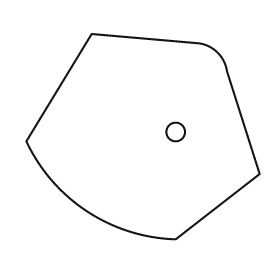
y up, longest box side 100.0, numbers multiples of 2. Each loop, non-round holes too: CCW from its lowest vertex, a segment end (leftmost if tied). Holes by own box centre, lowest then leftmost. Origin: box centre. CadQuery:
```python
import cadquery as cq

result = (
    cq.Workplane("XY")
    .moveTo(14.0, -44.0)
    .lineTo(50.0, -16.0)
    .lineTo(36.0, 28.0)
    .threePointArc((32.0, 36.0), (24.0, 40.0))
    .lineTo(-22.0, 44.0)
    .lineTo(-50.0, -2.0)
    .threePointArc((-24.0, -32.0), (14.0, -44.0))
    .close()
    .moveTo(14.0, 2.0)
    .circle(4.0)
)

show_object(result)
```